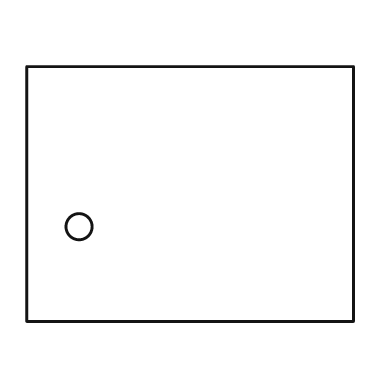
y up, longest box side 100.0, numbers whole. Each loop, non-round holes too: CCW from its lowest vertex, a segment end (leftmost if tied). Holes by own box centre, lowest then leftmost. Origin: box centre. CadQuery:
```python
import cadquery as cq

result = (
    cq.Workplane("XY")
    .moveTo(-50.0, -39.0)
    .lineTo(50.0, -39.0)
    .lineTo(50.0, 39.0)
    .lineTo(-50.0, 39.0)
    .close()
    .moveTo(-34.0, -10.0)
    .circle(4.0)
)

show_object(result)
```